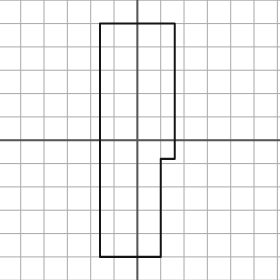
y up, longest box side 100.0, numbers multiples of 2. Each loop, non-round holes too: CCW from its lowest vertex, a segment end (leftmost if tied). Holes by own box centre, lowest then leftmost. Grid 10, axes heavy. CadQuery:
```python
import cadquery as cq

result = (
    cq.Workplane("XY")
    .moveTo(-16.0, -50.0)
    .lineTo(10.0, -50.0)
    .lineTo(10.0, -8.0)
    .lineTo(16.0, -8.0)
    .lineTo(16.0, 50.0)
    .lineTo(-16.0, 50.0)
    .close()
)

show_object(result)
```